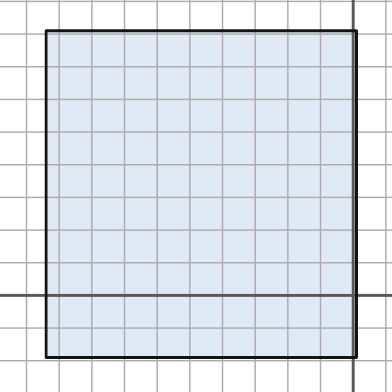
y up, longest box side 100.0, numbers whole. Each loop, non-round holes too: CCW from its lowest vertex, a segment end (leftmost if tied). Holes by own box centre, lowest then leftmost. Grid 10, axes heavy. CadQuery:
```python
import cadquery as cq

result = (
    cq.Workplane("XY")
    .moveTo(-94.0, -19.0)
    .lineTo(1.0, -19.0)
    .lineTo(1.0, 81.0)
    .lineTo(-94.0, 81.0)
    .close()
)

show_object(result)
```